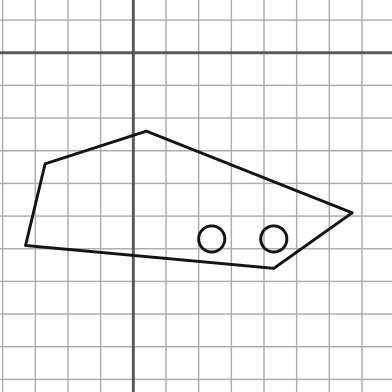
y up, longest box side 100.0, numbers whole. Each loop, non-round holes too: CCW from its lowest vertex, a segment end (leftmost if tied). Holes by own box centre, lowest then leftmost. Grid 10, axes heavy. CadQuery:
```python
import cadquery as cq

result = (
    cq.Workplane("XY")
    .moveTo(43.0, -66.0)
    .lineTo(67.0, -49.0)
    .lineTo(4.0, -24.0)
    .lineTo(-27.0, -34.0)
    .lineTo(-33.0, -59.0)
    .close()
    .moveTo(24.0, -57.0)
    .circle(4.0)
    .moveTo(43.0, -57.0)
    .circle(4.0)
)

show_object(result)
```